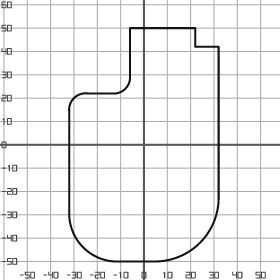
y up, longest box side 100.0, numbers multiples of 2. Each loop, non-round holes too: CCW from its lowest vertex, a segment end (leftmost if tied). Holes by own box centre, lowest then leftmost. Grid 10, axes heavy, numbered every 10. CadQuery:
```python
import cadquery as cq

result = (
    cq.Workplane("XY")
    .moveTo(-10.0, -50.0)
    .lineTo(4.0, -50.0)
    .threePointArc((24.0, -42.0), (32.0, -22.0))
    .lineTo(32.0, 42.0)
    .lineTo(22.0, 42.0)
    .lineTo(22.0, 50.0)
    .lineTo(-6.0, 50.0)
    .lineTo(-6.0, 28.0)
    .threePointArc((-8.0, 24.0), (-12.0, 22.0))
    .lineTo(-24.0, 22.0)
    .threePointArc((-30.0, 20.0), (-32.0, 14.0))
    .lineTo(-32.0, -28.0)
    .threePointArc((-26.0, -44.0), (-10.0, -50.0))
    .close()
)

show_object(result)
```